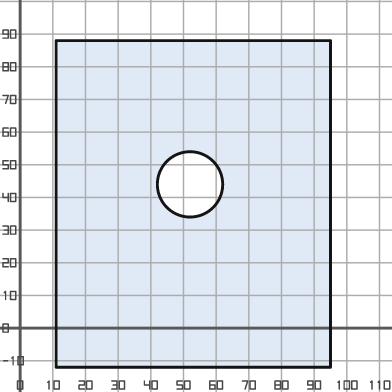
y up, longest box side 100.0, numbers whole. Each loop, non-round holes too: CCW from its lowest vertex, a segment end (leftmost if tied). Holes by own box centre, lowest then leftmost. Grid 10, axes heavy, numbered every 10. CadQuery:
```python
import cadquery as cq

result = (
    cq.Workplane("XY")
    .moveTo(11.0, -12.0)
    .lineTo(95.0, -12.0)
    .lineTo(95.0, 88.0)
    .lineTo(11.0, 88.0)
    .close()
    .moveTo(52.0, 44.0)
    .circle(10.0)
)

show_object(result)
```